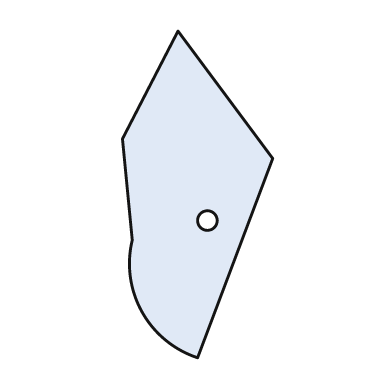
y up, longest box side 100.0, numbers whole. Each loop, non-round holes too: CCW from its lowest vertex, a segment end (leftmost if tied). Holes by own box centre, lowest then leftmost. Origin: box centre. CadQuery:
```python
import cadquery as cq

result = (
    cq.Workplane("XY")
    .moveTo(0.0, -50.0)
    .lineTo(23.0, 11.0)
    .lineTo(-6.0, 50.0)
    .lineTo(-23.0, 17.0)
    .lineTo(-20.0, -14.0)
    .threePointArc((-17.0, -36.0), (0.0, -50.0))
    .close()
    .moveTo(3.0, -8.0)
    .circle(3.0)
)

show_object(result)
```